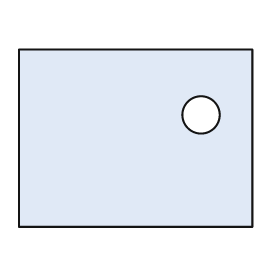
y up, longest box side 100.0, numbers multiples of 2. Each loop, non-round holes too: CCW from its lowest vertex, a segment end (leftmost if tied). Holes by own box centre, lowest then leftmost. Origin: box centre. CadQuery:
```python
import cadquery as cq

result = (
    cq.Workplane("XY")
    .moveTo(-50.0, -38.0)
    .lineTo(50.0, -38.0)
    .lineTo(50.0, 38.0)
    .lineTo(-50.0, 38.0)
    .close()
    .moveTo(28.0, 10.0)
    .circle(8.0)
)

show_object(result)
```